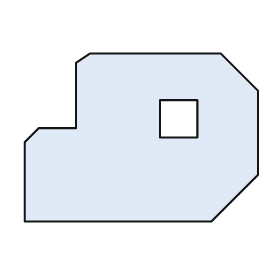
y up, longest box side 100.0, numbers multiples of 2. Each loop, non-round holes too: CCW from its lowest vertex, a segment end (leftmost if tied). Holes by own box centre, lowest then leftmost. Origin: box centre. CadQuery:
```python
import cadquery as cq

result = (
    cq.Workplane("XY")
    .moveTo(-50.0, -36.0)
    .lineTo(30.0, -36.0)
    .lineTo(50.0, -16.0)
    .lineTo(50.0, 20.0)
    .lineTo(34.0, 36.0)
    .lineTo(-22.0, 36.0)
    .lineTo(-28.0, 32.0)
    .lineTo(-28.0, 4.0)
    .lineTo(-44.0, 4.0)
    .lineTo(-50.0, -2.0)
    .close()
    .moveTo(8.0, 0.0)
    .lineTo(24.0, 0.0)
    .lineTo(24.0, 16.0)
    .lineTo(8.0, 16.0)
    .close()
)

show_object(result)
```